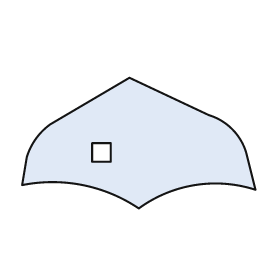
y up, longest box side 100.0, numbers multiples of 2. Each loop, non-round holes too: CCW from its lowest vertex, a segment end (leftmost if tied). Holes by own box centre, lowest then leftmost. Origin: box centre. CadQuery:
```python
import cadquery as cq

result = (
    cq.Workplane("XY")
    .moveTo(0.0, -28.0)
    .threePointArc((24.0, -18.0), (50.0, -20.0))
    .lineTo(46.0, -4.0)
    .threePointArc((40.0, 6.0), (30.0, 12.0))
    .lineTo(-4.0, 28.0)
    .lineTo(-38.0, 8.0)
    .threePointArc((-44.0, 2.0), (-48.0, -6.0))
    .lineTo(-50.0, -18.0)
    .threePointArc((-24.0, -18.0), (0.0, -28.0))
    .close()
    .moveTo(-20.0, -8.0)
    .lineTo(-12.0, -8.0)
    .lineTo(-12.0, 0.0)
    .lineTo(-20.0, 0.0)
    .close()
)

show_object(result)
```